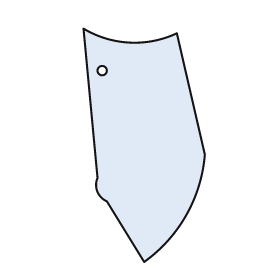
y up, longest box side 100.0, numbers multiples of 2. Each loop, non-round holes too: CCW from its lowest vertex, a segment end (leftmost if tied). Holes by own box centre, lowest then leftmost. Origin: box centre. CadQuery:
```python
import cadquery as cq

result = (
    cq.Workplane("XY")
    .moveTo(0.0, -50.0)
    .threePointArc((18.0, -30.0), (26.0, -4.0))
    .lineTo(14.0, 48.0)
    .threePointArc((-6.0, 44.0), (-26.0, 50.0))
    .lineTo(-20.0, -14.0)
    .threePointArc((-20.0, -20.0), (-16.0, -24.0))
    .close()
    .moveTo(-18.0, 32.0)
    .circle(2.0)
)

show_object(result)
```